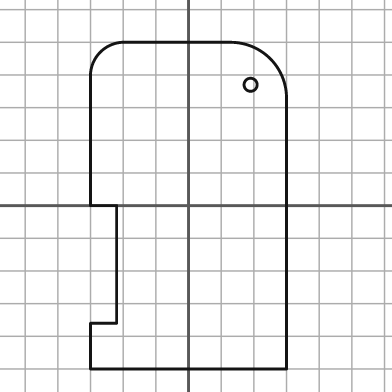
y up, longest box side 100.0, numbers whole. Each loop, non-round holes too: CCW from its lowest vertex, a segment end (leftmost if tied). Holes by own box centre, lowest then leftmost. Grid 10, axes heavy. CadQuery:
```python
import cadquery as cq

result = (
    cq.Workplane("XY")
    .moveTo(-30.0, -50.0)
    .lineTo(30.0, -50.0)
    .lineTo(30.0, 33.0)
    .threePointArc((25.0, 45.0), (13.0, 50.0))
    .lineTo(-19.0, 50.0)
    .threePointArc((-27.0, 47.0), (-30.0, 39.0))
    .lineTo(-30.0, 0.0)
    .lineTo(-22.0, 0.0)
    .lineTo(-22.0, -36.0)
    .lineTo(-30.0, -36.0)
    .close()
    .moveTo(19.0, 37.0)
    .circle(2.0)
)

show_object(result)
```